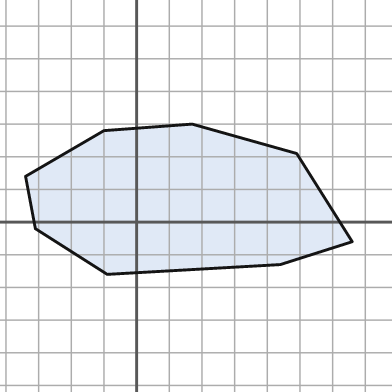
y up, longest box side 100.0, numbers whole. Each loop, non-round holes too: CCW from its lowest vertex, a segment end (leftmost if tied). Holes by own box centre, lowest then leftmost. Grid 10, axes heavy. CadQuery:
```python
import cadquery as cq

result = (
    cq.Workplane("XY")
    .moveTo(-9.0, -16.0)
    .lineTo(44.0, -13.0)
    .lineTo(66.0, -6.0)
    .lineTo(49.0, 21.0)
    .lineTo(17.0, 30.0)
    .lineTo(-10.0, 28.0)
    .lineTo(-34.0, 14.0)
    .lineTo(-31.0, -2.0)
    .close()
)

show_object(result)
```